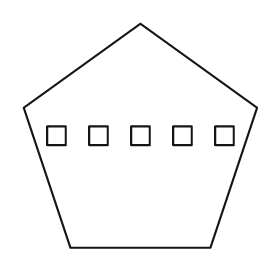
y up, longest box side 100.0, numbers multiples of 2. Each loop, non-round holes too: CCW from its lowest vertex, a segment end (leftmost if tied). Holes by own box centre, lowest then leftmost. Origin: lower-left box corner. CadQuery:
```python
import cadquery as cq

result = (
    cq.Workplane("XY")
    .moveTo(20.0, 0.0)
    .lineTo(80.0, 0.0)
    .lineTo(100.0, 60.0)
    .lineTo(50.0, 96.0)
    .lineTo(0.0, 60.0)
    .close()
    .moveTo(10.0, 44.0)
    .lineTo(18.0, 44.0)
    .lineTo(18.0, 52.0)
    .lineTo(10.0, 52.0)
    .close()
    .moveTo(28.0, 44.0)
    .lineTo(36.0, 44.0)
    .lineTo(36.0, 52.0)
    .lineTo(28.0, 52.0)
    .close()
    .moveTo(46.0, 44.0)
    .lineTo(54.0, 44.0)
    .lineTo(54.0, 52.0)
    .lineTo(46.0, 52.0)
    .close()
    .moveTo(64.0, 44.0)
    .lineTo(72.0, 44.0)
    .lineTo(72.0, 52.0)
    .lineTo(64.0, 52.0)
    .close()
    .moveTo(82.0, 44.0)
    .lineTo(90.0, 44.0)
    .lineTo(90.0, 52.0)
    .lineTo(82.0, 52.0)
    .close()
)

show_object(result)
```